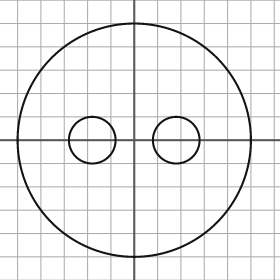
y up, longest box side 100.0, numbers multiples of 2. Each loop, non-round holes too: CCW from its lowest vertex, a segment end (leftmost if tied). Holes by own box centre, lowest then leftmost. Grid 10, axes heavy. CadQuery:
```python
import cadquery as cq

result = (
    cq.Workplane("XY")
    .moveTo(0.0, 0.0)
    .circle(50.0)
    .moveTo(-18.0, 0.0)
    .circle(10.0)
    .moveTo(18.0, 0.0)
    .circle(10.0)
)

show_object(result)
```